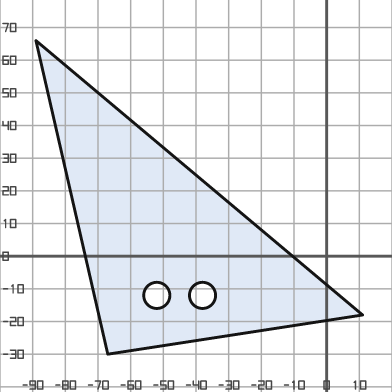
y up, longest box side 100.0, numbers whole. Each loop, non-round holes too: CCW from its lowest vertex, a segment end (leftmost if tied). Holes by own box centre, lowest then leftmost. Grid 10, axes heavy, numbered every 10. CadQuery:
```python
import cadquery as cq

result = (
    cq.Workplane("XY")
    .moveTo(-67.0, -30.0)
    .lineTo(11.0, -18.0)
    .lineTo(-89.0, 66.0)
    .close()
    .moveTo(-52.0, -12.0)
    .circle(4.0)
    .moveTo(-38.0, -12.0)
    .circle(4.0)
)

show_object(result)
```